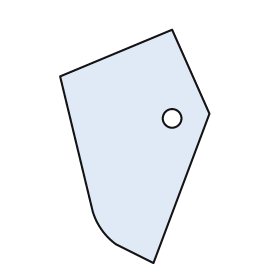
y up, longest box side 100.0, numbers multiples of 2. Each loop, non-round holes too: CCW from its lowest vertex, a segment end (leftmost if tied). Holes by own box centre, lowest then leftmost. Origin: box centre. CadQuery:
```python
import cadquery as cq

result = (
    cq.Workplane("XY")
    .moveTo(8.0, -50.0)
    .lineTo(32.0, 14.0)
    .lineTo(16.0, 50.0)
    .lineTo(-32.0, 30.0)
    .lineTo(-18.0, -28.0)
    .threePointArc((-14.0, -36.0), (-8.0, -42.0))
    .close()
    .moveTo(16.0, 12.0)
    .circle(4.0)
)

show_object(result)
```